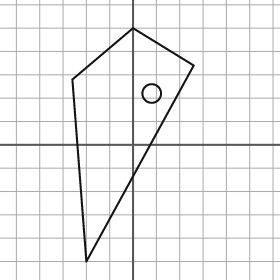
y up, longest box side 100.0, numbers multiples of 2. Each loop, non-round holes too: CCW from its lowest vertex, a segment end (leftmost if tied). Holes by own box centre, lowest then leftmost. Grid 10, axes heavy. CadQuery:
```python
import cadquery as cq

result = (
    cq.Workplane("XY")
    .moveTo(-20.0, -50.0)
    .lineTo(26.0, 34.0)
    .lineTo(0.0, 50.0)
    .lineTo(-26.0, 28.0)
    .close()
    .moveTo(8.0, 22.0)
    .circle(4.0)
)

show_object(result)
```